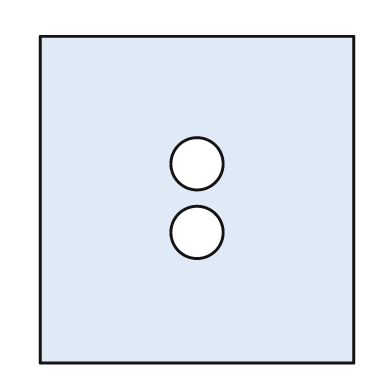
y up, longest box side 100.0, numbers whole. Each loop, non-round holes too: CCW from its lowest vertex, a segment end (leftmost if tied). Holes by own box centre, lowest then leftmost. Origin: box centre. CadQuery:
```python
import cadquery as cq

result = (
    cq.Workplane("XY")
    .moveTo(-48.0, -50.0)
    .lineTo(48.0, -50.0)
    .lineTo(48.0, 50.0)
    .lineTo(-48.0, 50.0)
    .close()
    .moveTo(0.0, -10.0)
    .circle(8.0)
    .moveTo(0.0, 11.0)
    .circle(8.0)
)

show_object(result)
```